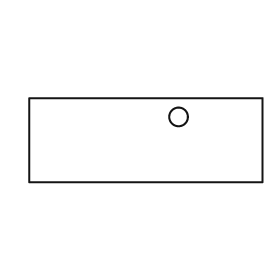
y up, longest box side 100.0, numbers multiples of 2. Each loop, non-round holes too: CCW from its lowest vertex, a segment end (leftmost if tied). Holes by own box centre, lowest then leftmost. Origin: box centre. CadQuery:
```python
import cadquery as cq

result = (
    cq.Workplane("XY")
    .moveTo(-50.0, -18.0)
    .lineTo(50.0, -18.0)
    .lineTo(50.0, 18.0)
    .lineTo(-50.0, 18.0)
    .close()
    .moveTo(14.0, 10.0)
    .circle(4.0)
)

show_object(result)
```